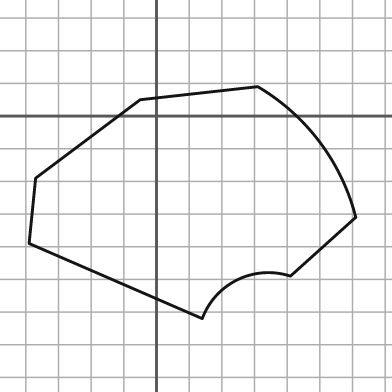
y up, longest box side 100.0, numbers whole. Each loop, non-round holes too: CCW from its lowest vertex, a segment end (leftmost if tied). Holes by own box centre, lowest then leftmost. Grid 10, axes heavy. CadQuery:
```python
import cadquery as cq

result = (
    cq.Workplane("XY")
    .moveTo(14.0, -62.0)
    .threePointArc((25.0, -50.0), (41.0, -49.0))
    .lineTo(61.0, -31.0)
    .threePointArc((50.0, -8.0), (31.0, 9.0))
    .lineTo(-5.0, 5.0)
    .lineTo(-37.0, -19.0)
    .lineTo(-39.0, -39.0)
    .close()
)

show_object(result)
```